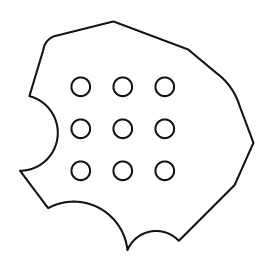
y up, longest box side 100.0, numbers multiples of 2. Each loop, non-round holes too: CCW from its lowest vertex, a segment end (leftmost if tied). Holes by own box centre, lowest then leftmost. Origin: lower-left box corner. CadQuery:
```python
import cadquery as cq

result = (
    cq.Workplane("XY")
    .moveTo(46.0, 0.0)
    .threePointArc((56.0, 8.0), (68.0, 4.0))
    .lineTo(92.0, 28.0)
    .lineTo(100.0, 46.0)
    .lineTo(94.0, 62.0)
    .threePointArc((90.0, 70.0), (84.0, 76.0))
    .lineTo(72.0, 86.0)
    .lineTo(40.0, 98.0)
    .lineTo(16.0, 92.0)
    .threePointArc((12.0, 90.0), (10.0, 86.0))
    .lineTo(4.0, 66.0)
    .threePointArc((16.0, 48.0), (0.0, 34.0))
    .lineTo(12.0, 18.0)
    .threePointArc((34.0, 18.0), (46.0, 0.0))
    .close()
    .moveTo(26.0, 34.0)
    .circle(4.0)
    .moveTo(44.0, 34.0)
    .circle(4.0)
    .moveTo(62.0, 34.0)
    .circle(4.0)
    .moveTo(26.0, 52.0)
    .circle(4.0)
    .moveTo(44.0, 52.0)
    .circle(4.0)
    .moveTo(62.0, 52.0)
    .circle(4.0)
    .moveTo(26.0, 70.0)
    .circle(4.0)
    .moveTo(44.0, 70.0)
    .circle(4.0)
    .moveTo(62.0, 70.0)
    .circle(4.0)
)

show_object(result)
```